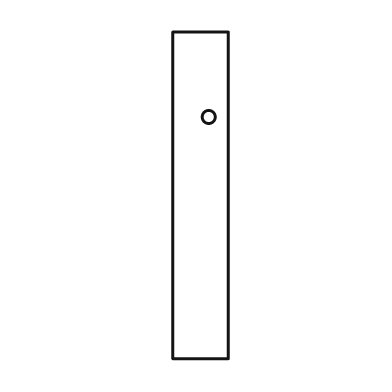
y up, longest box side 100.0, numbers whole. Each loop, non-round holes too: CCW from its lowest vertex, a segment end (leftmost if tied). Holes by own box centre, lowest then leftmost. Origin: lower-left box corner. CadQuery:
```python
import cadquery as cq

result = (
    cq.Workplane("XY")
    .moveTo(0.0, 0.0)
    .lineTo(17.0, 0.0)
    .lineTo(17.0, 100.0)
    .lineTo(0.0, 100.0)
    .close()
    .moveTo(11.0, 74.0)
    .circle(2.0)
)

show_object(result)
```